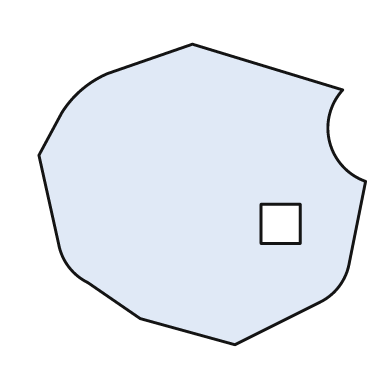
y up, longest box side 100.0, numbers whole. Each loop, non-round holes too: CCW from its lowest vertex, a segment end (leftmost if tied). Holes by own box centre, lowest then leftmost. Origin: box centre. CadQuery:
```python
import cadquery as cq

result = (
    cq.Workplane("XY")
    .moveTo(10.0, -46.0)
    .lineTo(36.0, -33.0)
    .threePointArc((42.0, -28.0), (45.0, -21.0))
    .lineTo(50.0, 4.0)
    .threePointArc((39.0, 16.0), (43.0, 32.0))
    .lineTo(-3.0, 46.0)
    .lineTo(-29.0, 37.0)
    .threePointArc((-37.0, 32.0), (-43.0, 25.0))
    .lineTo(-50.0, 12.0)
    .lineTo(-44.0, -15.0)
    .threePointArc((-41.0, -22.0), (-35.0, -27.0))
    .lineTo(-19.0, -38.0)
    .close()
    .moveTo(18.0, -15.0)
    .lineTo(30.0, -15.0)
    .lineTo(30.0, -3.0)
    .lineTo(18.0, -3.0)
    .close()
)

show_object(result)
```